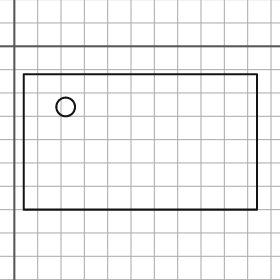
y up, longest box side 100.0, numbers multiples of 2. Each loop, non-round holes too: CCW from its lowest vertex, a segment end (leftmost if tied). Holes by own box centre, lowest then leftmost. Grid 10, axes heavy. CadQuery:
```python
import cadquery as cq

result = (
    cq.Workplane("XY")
    .moveTo(4.0, -70.0)
    .lineTo(104.0, -70.0)
    .lineTo(104.0, -12.0)
    .lineTo(4.0, -12.0)
    .close()
    .moveTo(22.0, -26.0)
    .circle(4.0)
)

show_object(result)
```